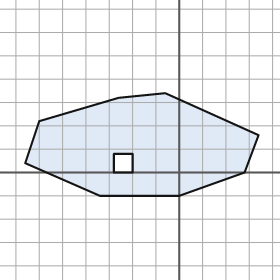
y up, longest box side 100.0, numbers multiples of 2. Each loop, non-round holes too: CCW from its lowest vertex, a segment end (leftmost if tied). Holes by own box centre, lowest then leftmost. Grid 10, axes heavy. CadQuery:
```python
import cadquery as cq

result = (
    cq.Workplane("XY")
    .moveTo(-34.0, -10.0)
    .lineTo(0.0, -10.0)
    .lineTo(28.0, 0.0)
    .lineTo(34.0, 16.0)
    .lineTo(-6.0, 34.0)
    .lineTo(-26.0, 32.0)
    .lineTo(-60.0, 22.0)
    .lineTo(-66.0, 4.0)
    .close()
    .moveTo(-28.0, 0.0)
    .lineTo(-20.0, 0.0)
    .lineTo(-20.0, 8.0)
    .lineTo(-28.0, 8.0)
    .close()
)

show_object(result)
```